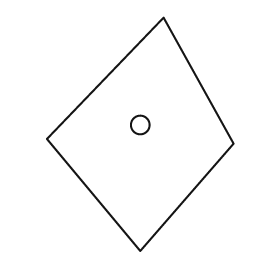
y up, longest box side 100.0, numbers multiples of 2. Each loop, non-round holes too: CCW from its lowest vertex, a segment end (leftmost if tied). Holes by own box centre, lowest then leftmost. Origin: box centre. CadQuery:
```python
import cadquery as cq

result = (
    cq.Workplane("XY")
    .moveTo(0.0, -50.0)
    .lineTo(40.0, -4.0)
    .lineTo(10.0, 50.0)
    .lineTo(-40.0, -2.0)
    .close()
    .moveTo(0.0, 4.0)
    .circle(4.0)
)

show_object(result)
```